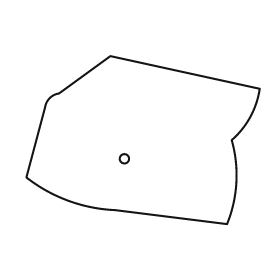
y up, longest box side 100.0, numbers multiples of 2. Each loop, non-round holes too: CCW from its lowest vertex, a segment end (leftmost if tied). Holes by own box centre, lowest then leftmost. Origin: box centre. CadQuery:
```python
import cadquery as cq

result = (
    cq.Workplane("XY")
    .moveTo(36.0, -36.0)
    .threePointArc((40.0, -18.0), (38.0, 0.0))
    .threePointArc((46.0, 10.0), (50.0, 22.0))
    .lineTo(-14.0, 36.0)
    .lineTo(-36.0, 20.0)
    .threePointArc((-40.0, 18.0), (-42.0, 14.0))
    .lineTo(-50.0, -16.0)
    .threePointArc((-32.0, -26.0), (-12.0, -30.0))
    .close()
    .moveTo(-8.0, -8.0)
    .circle(2.0)
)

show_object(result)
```